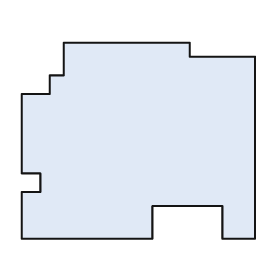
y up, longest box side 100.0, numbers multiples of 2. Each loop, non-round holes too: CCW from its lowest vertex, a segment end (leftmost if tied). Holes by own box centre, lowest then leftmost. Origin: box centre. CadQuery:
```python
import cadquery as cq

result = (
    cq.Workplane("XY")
    .moveTo(-50.0, -42.0)
    .lineTo(6.0, -42.0)
    .lineTo(6.0, -28.0)
    .lineTo(36.0, -28.0)
    .lineTo(36.0, -42.0)
    .lineTo(50.0, -42.0)
    .lineTo(50.0, 36.0)
    .lineTo(22.0, 36.0)
    .lineTo(22.0, 42.0)
    .lineTo(-32.0, 42.0)
    .lineTo(-32.0, 28.0)
    .lineTo(-38.0, 28.0)
    .lineTo(-38.0, 20.0)
    .lineTo(-50.0, 20.0)
    .lineTo(-50.0, -14.0)
    .lineTo(-42.0, -14.0)
    .lineTo(-42.0, -22.0)
    .lineTo(-50.0, -22.0)
    .close()
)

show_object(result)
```